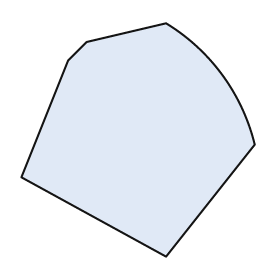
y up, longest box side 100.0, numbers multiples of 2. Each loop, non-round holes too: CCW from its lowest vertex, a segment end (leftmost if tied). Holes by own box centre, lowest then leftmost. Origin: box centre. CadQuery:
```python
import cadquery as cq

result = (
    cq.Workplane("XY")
    .moveTo(12.0, -50.0)
    .lineTo(50.0, -2.0)
    .threePointArc((36.0, 28.0), (12.0, 50.0))
    .lineTo(-22.0, 42.0)
    .lineTo(-30.0, 34.0)
    .lineTo(-50.0, -16.0)
    .close()
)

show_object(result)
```